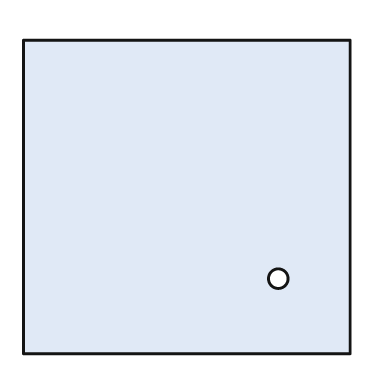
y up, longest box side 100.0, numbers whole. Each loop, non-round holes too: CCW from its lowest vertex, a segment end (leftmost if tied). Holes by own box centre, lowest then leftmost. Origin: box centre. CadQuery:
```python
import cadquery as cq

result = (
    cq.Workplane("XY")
    .moveTo(-50.0, -48.0)
    .lineTo(50.0, -48.0)
    .lineTo(50.0, 48.0)
    .lineTo(-50.0, 48.0)
    .close()
    .moveTo(28.0, -25.0)
    .circle(3.0)
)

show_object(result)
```